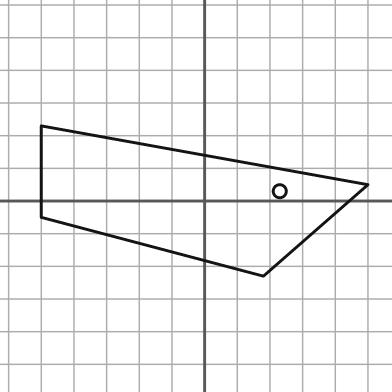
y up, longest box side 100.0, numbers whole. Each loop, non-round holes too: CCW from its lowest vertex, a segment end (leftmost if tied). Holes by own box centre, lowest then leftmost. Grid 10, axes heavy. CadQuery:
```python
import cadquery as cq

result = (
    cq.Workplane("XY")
    .moveTo(18.0, -23.0)
    .lineTo(50.0, 5.0)
    .lineTo(-50.0, 23.0)
    .lineTo(-50.0, -5.0)
    .close()
    .moveTo(23.0, 3.0)
    .circle(2.0)
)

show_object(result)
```